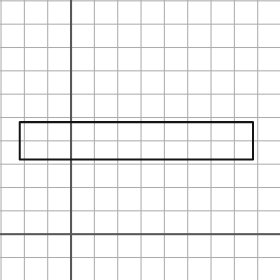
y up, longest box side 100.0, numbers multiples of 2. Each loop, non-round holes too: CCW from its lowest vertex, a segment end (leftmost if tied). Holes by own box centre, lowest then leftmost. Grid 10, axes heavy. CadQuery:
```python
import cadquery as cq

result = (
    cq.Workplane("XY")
    .moveTo(-22.0, 32.0)
    .lineTo(78.0, 32.0)
    .lineTo(78.0, 48.0)
    .lineTo(-22.0, 48.0)
    .close()
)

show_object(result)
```